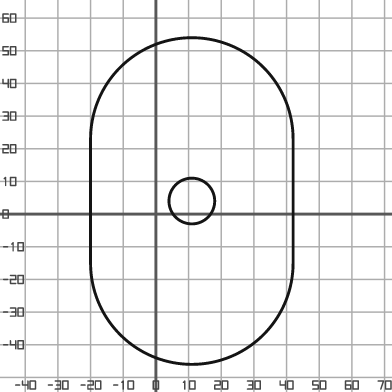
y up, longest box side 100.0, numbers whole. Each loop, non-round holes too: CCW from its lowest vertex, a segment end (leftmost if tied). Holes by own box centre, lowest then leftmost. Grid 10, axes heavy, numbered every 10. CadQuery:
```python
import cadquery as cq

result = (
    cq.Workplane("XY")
    .moveTo(-20.0, -15.0)
    .threePointArc((11.0, -46.0), (42.0, -15.0))
    .lineTo(42.0, 23.0)
    .threePointArc((11.0, 54.0), (-20.0, 23.0))
    .close()
    .moveTo(11.0, 4.0)
    .circle(7.0)
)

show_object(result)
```